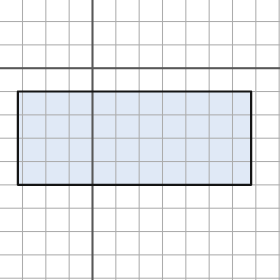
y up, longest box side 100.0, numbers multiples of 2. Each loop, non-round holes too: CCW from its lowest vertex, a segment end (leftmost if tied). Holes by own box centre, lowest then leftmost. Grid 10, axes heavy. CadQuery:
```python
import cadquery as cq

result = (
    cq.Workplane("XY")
    .moveTo(-32.0, -50.0)
    .lineTo(68.0, -50.0)
    .lineTo(68.0, -10.0)
    .lineTo(-32.0, -10.0)
    .close()
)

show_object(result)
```